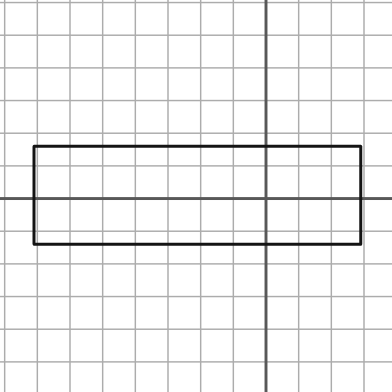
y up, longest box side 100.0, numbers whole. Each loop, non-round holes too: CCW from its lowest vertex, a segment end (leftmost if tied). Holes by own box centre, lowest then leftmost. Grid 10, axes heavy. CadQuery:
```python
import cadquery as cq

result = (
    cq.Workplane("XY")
    .moveTo(-71.0, -14.0)
    .lineTo(29.0, -14.0)
    .lineTo(29.0, 16.0)
    .lineTo(-71.0, 16.0)
    .close()
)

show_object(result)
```